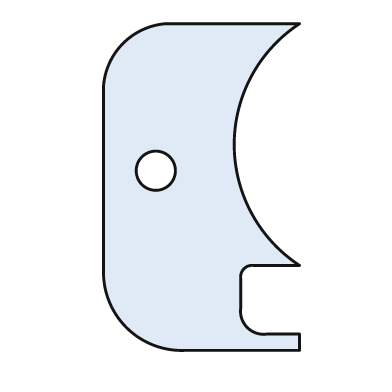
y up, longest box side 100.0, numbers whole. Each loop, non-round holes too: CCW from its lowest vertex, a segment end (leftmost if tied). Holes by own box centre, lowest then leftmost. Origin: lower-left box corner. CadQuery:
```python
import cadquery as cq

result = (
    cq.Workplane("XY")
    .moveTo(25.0, 0.0)
    .lineTo(60.0, 0.0)
    .lineTo(60.0, 5.0)
    .lineTo(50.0, 5.0)
    .threePointArc((44.0, 7.0), (42.0, 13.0))
    .lineTo(42.0, 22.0)
    .threePointArc((43.0, 25.0), (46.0, 26.0))
    .lineTo(60.0, 26.0)
    .threePointArc((40.0, 63.0), (60.0, 100.0))
    .lineTo(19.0, 100.0)
    .threePointArc((6.0, 94.0), (0.0, 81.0))
    .lineTo(0.0, 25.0)
    .threePointArc((7.0, 7.0), (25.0, 0.0))
    .close()
    .moveTo(16.0, 55.0)
    .circle(6.0)
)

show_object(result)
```